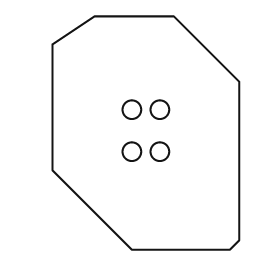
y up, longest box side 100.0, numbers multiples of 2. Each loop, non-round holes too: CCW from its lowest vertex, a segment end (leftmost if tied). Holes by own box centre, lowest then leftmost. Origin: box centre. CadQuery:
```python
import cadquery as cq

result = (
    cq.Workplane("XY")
    .moveTo(-6.0, -50.0)
    .lineTo(36.0, -50.0)
    .lineTo(40.0, -46.0)
    .lineTo(40.0, 22.0)
    .lineTo(12.0, 50.0)
    .lineTo(-22.0, 50.0)
    .lineTo(-40.0, 38.0)
    .lineTo(-40.0, -16.0)
    .close()
    .moveTo(-6.0, -8.0)
    .circle(4.0)
    .moveTo(6.0, -8.0)
    .circle(4.0)
    .moveTo(-6.0, 10.0)
    .circle(4.0)
    .moveTo(6.0, 10.0)
    .circle(4.0)
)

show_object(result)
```